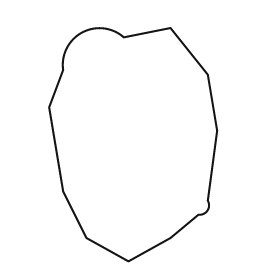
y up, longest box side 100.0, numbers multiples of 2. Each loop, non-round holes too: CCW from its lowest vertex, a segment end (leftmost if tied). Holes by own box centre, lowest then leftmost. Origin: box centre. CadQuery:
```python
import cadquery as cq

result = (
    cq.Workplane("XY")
    .moveTo(-2.0, -50.0)
    .lineTo(16.0, -40.0)
    .lineTo(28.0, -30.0)
    .threePointArc((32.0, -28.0), (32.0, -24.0))
    .lineTo(36.0, 6.0)
    .lineTo(32.0, 30.0)
    .lineTo(16.0, 50.0)
    .lineTo(-4.0, 46.0)
    .threePointArc((-22.0, 48.0), (-30.0, 32.0))
    .lineTo(-36.0, 16.0)
    .lineTo(-30.0, -20.0)
    .lineTo(-20.0, -40.0)
    .close()
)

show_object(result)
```